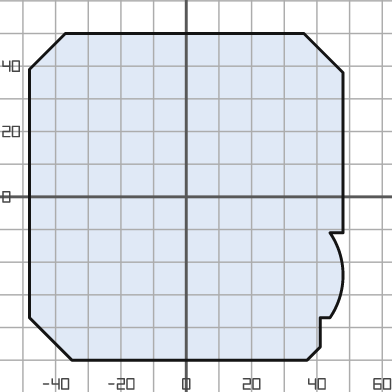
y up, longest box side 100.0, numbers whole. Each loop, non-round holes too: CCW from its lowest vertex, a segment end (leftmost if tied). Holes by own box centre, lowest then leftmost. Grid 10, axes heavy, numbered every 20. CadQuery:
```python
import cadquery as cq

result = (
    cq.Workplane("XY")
    .moveTo(-35.0, -50.0)
    .lineTo(37.0, -50.0)
    .lineTo(41.0, -46.0)
    .lineTo(41.0, -37.0)
    .lineTo(44.0, -37.0)
    .threePointArc((48.0, -24.0), (44.0, -11.0))
    .lineTo(48.0, -11.0)
    .lineTo(48.0, 38.0)
    .lineTo(36.0, 50.0)
    .lineTo(-37.0, 50.0)
    .lineTo(-48.0, 39.0)
    .lineTo(-48.0, -37.0)
    .close()
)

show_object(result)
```